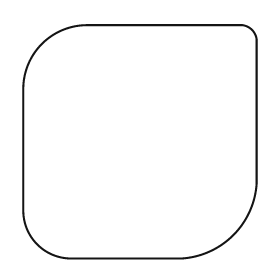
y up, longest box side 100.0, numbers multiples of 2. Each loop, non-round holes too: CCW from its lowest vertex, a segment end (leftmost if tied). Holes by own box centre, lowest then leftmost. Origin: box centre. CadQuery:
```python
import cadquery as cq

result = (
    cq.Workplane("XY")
    .moveTo(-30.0, -50.0)
    .lineTo(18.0, -50.0)
    .threePointArc((40.0, -40.0), (50.0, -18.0))
    .lineTo(50.0, 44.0)
    .threePointArc((48.0, 48.0), (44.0, 50.0))
    .lineTo(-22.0, 50.0)
    .threePointArc((-42.0, 42.0), (-50.0, 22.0))
    .lineTo(-50.0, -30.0)
    .threePointArc((-44.0, -44.0), (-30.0, -50.0))
    .close()
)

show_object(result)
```